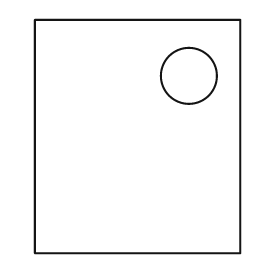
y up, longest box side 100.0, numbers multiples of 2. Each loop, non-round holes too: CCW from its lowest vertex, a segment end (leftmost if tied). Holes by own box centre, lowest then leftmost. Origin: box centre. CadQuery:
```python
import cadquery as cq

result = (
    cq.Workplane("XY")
    .moveTo(-44.0, -50.0)
    .lineTo(44.0, -50.0)
    .lineTo(44.0, 50.0)
    .lineTo(-44.0, 50.0)
    .close()
    .moveTo(22.0, 26.0)
    .circle(12.0)
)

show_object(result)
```